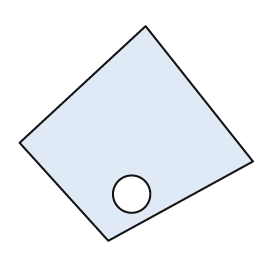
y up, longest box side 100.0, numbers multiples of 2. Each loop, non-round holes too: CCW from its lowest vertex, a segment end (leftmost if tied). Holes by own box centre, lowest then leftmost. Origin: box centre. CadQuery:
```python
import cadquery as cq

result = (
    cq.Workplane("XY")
    .moveTo(-12.0, -46.0)
    .lineTo(50.0, -12.0)
    .lineTo(4.0, 46.0)
    .lineTo(-50.0, -4.0)
    .close()
    .moveTo(-2.0, -26.0)
    .circle(8.0)
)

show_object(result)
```